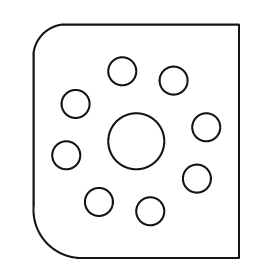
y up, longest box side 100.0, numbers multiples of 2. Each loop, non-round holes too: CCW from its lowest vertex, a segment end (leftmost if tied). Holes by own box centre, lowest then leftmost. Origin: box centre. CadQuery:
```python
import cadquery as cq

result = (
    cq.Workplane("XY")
    .moveTo(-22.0, -50.0)
    .lineTo(44.0, -50.0)
    .lineTo(44.0, 50.0)
    .lineTo(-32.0, 50.0)
    .threePointArc((-40.0, 46.0), (-44.0, 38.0))
    .lineTo(-44.0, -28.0)
    .threePointArc((-38.0, -44.0), (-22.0, -50.0))
    .close()
    .moveTo(6.0, -30.0)
    .circle(6.0)
    .moveTo(-16.0, -26.0)
    .circle(6.0)
    .moveTo(26.0, -16.0)
    .circle(6.0)
    .moveTo(-30.0, -6.0)
    .circle(6.0)
    .moveTo(0.0, 0.0)
    .circle(12.0)
    .moveTo(30.0, 6.0)
    .circle(6.0)
    .moveTo(-26.0, 16.0)
    .circle(6.0)
    .moveTo(16.0, 26.0)
    .circle(6.0)
    .moveTo(-6.0, 30.0)
    .circle(6.0)
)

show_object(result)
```